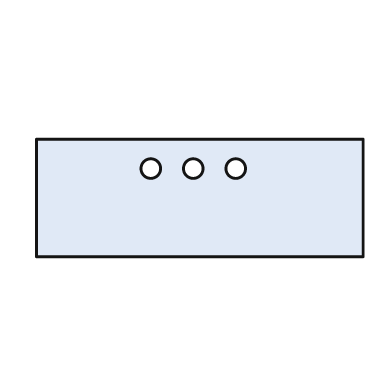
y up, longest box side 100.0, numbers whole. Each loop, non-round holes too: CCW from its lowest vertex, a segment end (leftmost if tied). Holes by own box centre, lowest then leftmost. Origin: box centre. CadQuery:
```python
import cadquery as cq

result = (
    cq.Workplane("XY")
    .moveTo(-50.0, -18.0)
    .lineTo(50.0, -18.0)
    .lineTo(50.0, 18.0)
    .lineTo(-50.0, 18.0)
    .close()
    .moveTo(-15.0, 9.0)
    .circle(3.0)
    .moveTo(-2.0, 9.0)
    .circle(3.0)
    .moveTo(11.0, 9.0)
    .circle(3.0)
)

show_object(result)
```